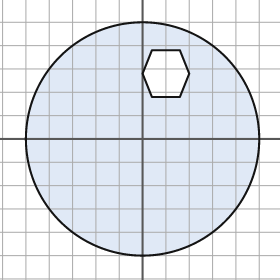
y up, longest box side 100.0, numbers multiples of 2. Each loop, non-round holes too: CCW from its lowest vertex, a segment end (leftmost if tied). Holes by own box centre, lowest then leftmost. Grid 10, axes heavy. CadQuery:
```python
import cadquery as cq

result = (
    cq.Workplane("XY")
    .moveTo(0.0, 0.0)
    .circle(50.0)
    .moveTo(4.0, 18.0)
    .lineTo(16.0, 18.0)
    .lineTo(20.0, 28.0)
    .lineTo(16.0, 38.0)
    .lineTo(4.0, 38.0)
    .lineTo(0.0, 28.0)
    .close()
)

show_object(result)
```